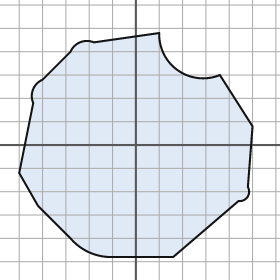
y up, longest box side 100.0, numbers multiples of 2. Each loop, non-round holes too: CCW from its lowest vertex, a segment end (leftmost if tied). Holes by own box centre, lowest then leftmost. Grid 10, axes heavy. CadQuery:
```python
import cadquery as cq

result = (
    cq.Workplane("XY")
    .moveTo(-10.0, -48.0)
    .lineTo(16.0, -48.0)
    .lineTo(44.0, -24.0)
    .threePointArc((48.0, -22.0), (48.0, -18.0))
    .lineTo(50.0, 8.0)
    .lineTo(36.0, 30.0)
    .threePointArc((18.0, 32.0), (10.0, 48.0))
    .lineTo(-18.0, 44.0)
    .threePointArc((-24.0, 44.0), (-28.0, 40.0))
    .lineTo(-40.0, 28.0)
    .threePointArc((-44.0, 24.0), (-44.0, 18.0))
    .lineTo(-50.0, -12.0)
    .lineTo(-42.0, -26.0)
    .lineTo(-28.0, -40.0)
    .threePointArc((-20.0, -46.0), (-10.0, -48.0))
    .close()
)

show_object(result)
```